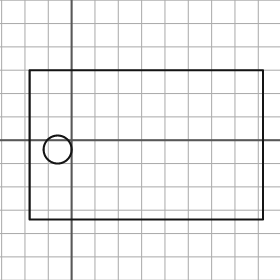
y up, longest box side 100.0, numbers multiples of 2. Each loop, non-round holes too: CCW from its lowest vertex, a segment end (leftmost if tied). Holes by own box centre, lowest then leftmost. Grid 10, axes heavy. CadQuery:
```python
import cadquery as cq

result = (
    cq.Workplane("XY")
    .moveTo(-18.0, -34.0)
    .lineTo(82.0, -34.0)
    .lineTo(82.0, 30.0)
    .lineTo(-18.0, 30.0)
    .close()
    .moveTo(-6.0, -4.0)
    .circle(6.0)
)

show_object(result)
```